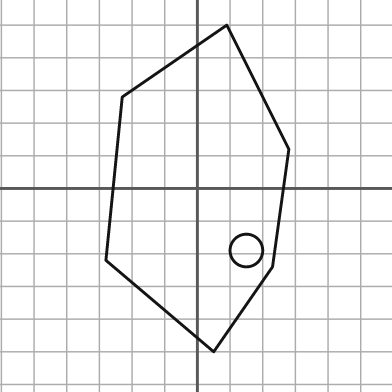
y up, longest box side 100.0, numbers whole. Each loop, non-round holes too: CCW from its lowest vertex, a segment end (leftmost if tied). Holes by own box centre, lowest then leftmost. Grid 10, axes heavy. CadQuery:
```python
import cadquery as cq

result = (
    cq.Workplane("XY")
    .moveTo(5.0, -50.0)
    .lineTo(23.0, -24.0)
    .lineTo(28.0, 12.0)
    .lineTo(9.0, 50.0)
    .lineTo(-23.0, 28.0)
    .lineTo(-28.0, -22.0)
    .close()
    .moveTo(15.0, -19.0)
    .circle(5.0)
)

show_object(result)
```